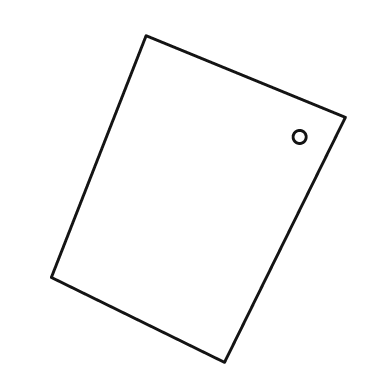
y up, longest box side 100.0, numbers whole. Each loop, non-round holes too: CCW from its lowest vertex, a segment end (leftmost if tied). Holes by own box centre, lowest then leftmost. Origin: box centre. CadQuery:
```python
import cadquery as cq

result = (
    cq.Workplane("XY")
    .moveTo(8.0, -50.0)
    .lineTo(45.0, 25.0)
    .lineTo(-16.0, 50.0)
    .lineTo(-45.0, -24.0)
    .close()
    .moveTo(31.0, 19.0)
    .circle(2.0)
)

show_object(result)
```